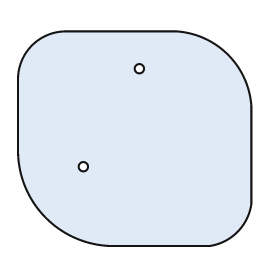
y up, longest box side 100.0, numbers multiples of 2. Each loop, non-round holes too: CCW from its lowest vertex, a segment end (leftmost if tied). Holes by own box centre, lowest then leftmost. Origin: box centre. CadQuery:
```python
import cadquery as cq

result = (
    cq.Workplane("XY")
    .moveTo(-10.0, -46.0)
    .lineTo(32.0, -46.0)
    .threePointArc((44.0, -40.0), (50.0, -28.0))
    .lineTo(50.0, 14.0)
    .threePointArc((40.0, 36.0), (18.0, 46.0))
    .lineTo(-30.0, 46.0)
    .threePointArc((-44.0, 40.0), (-50.0, 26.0))
    .lineTo(-50.0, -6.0)
    .threePointArc((-38.0, -34.0), (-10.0, -46.0))
    .close()
    .moveTo(-22.0, -12.0)
    .circle(2.0)
    .moveTo(2.0, 30.0)
    .circle(2.0)
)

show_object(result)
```